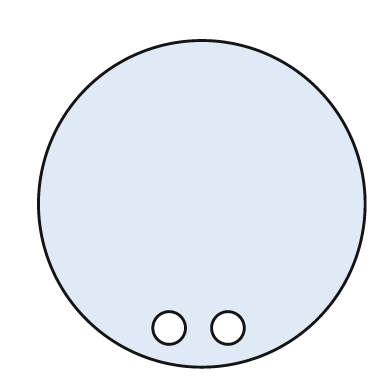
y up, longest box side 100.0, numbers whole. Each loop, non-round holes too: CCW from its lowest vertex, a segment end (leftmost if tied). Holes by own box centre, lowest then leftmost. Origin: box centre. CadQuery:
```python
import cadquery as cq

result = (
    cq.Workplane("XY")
    .moveTo(0.0, 0.0)
    .circle(50.0)
    .moveTo(-10.0, -38.0)
    .circle(5.0)
    .moveTo(8.0, -38.0)
    .circle(5.0)
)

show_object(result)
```